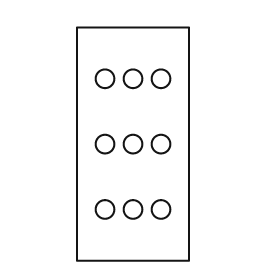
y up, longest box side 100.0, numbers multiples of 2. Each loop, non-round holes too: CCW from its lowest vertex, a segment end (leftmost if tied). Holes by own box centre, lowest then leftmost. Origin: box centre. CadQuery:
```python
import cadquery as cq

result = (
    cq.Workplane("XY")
    .moveTo(-24.0, -50.0)
    .lineTo(24.0, -50.0)
    .lineTo(24.0, 50.0)
    .lineTo(-24.0, 50.0)
    .close()
    .moveTo(-12.0, -28.0)
    .circle(4.0)
    .moveTo(0.0, -28.0)
    .circle(4.0)
    .moveTo(12.0, -28.0)
    .circle(4.0)
    .moveTo(-12.0, 0.0)
    .circle(4.0)
    .moveTo(0.0, 0.0)
    .circle(4.0)
    .moveTo(12.0, 0.0)
    .circle(4.0)
    .moveTo(-12.0, 28.0)
    .circle(4.0)
    .moveTo(0.0, 28.0)
    .circle(4.0)
    .moveTo(12.0, 28.0)
    .circle(4.0)
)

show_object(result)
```